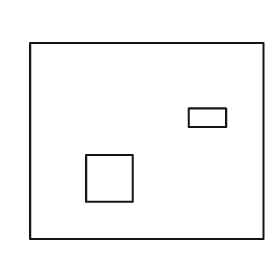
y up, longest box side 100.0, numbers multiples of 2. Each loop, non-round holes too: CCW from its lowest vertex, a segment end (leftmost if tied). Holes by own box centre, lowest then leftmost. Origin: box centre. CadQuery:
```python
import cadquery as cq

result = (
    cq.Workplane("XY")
    .moveTo(-50.0, -42.0)
    .lineTo(50.0, -42.0)
    .lineTo(50.0, 42.0)
    .lineTo(-50.0, 42.0)
    .close()
    .moveTo(-26.0, -26.0)
    .lineTo(-6.0, -26.0)
    .lineTo(-6.0, -6.0)
    .lineTo(-26.0, -6.0)
    .close()
    .moveTo(18.0, 6.0)
    .lineTo(34.0, 6.0)
    .lineTo(34.0, 14.0)
    .lineTo(18.0, 14.0)
    .close()
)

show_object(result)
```